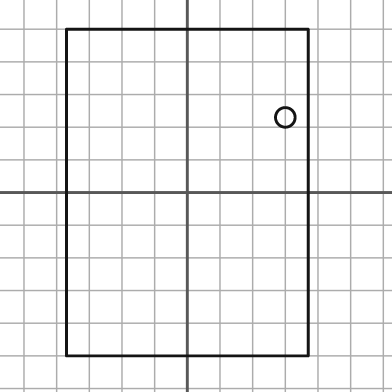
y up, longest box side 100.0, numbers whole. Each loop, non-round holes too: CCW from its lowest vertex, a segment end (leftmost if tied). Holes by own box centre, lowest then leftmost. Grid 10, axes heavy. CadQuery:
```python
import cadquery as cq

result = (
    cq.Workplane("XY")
    .moveTo(-37.0, -50.0)
    .lineTo(37.0, -50.0)
    .lineTo(37.0, 50.0)
    .lineTo(-37.0, 50.0)
    .close()
    .moveTo(30.0, 23.0)
    .circle(3.0)
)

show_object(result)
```